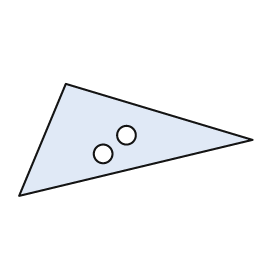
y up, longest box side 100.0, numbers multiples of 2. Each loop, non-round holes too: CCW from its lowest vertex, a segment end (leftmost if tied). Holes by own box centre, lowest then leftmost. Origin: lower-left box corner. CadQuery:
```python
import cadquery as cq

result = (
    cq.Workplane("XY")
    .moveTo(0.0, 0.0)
    .lineTo(100.0, 24.0)
    .lineTo(20.0, 48.0)
    .close()
    .moveTo(36.0, 18.0)
    .circle(4.0)
    .moveTo(46.0, 26.0)
    .circle(4.0)
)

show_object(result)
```